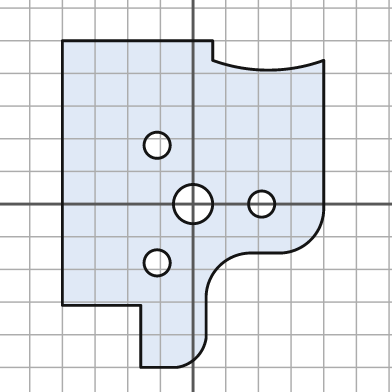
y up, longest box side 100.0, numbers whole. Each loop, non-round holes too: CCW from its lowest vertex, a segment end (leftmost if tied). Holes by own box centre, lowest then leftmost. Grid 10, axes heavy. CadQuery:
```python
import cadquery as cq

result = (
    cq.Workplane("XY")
    .moveTo(-16.0, -50.0)
    .lineTo(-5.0, -50.0)
    .threePointArc((1.0, -47.0), (4.0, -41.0))
    .lineTo(4.0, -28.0)
    .threePointArc((8.0, -19.0), (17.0, -15.0))
    .lineTo(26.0, -15.0)
    .threePointArc((36.0, -11.0), (40.0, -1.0))
    .lineTo(40.0, 44.0)
    .threePointArc((23.0, 41.0), (6.0, 44.0))
    .lineTo(6.0, 50.0)
    .lineTo(-40.0, 50.0)
    .lineTo(-40.0, -31.0)
    .lineTo(-16.0, -31.0)
    .close()
    .moveTo(-11.0, -18.0)
    .circle(4.0)
    .moveTo(0.0, 0.0)
    .circle(6.0)
    .moveTo(21.0, 0.0)
    .circle(4.0)
    .moveTo(-11.0, 18.0)
    .circle(4.0)
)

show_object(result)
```